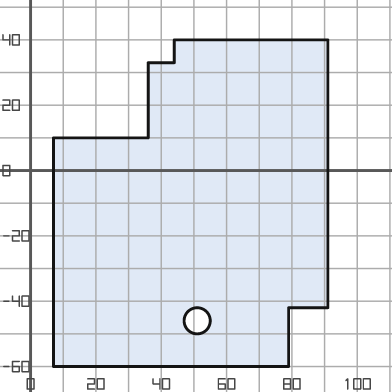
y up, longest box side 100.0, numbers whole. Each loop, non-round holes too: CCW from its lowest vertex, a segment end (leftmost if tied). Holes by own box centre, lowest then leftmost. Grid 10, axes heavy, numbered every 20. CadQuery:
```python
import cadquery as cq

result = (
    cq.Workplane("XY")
    .moveTo(7.0, -60.0)
    .lineTo(79.0, -60.0)
    .lineTo(79.0, -42.0)
    .lineTo(91.0, -42.0)
    .lineTo(91.0, 40.0)
    .lineTo(44.0, 40.0)
    .lineTo(44.0, 33.0)
    .lineTo(36.0, 33.0)
    .lineTo(36.0, 10.0)
    .lineTo(7.0, 10.0)
    .close()
    .moveTo(51.0, -46.0)
    .circle(4.0)
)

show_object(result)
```